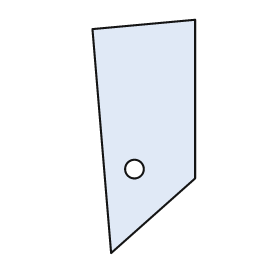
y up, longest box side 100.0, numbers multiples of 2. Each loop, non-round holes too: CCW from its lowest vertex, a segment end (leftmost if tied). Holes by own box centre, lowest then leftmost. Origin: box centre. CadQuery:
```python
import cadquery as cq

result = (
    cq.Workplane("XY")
    .moveTo(-14.0, -50.0)
    .lineTo(22.0, -18.0)
    .lineTo(22.0, 50.0)
    .lineTo(-22.0, 46.0)
    .close()
    .moveTo(-4.0, -14.0)
    .circle(4.0)
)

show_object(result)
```